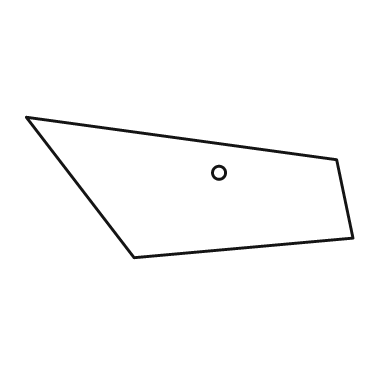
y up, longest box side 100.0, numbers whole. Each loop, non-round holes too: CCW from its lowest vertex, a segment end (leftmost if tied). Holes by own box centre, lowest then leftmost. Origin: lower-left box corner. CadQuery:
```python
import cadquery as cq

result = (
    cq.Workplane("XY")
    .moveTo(33.0, 0.0)
    .lineTo(100.0, 6.0)
    .lineTo(95.0, 30.0)
    .lineTo(0.0, 43.0)
    .close()
    .moveTo(59.0, 26.0)
    .circle(2.0)
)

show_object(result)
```